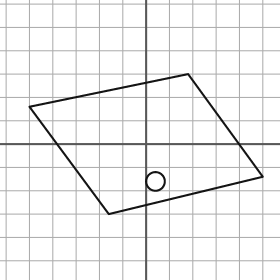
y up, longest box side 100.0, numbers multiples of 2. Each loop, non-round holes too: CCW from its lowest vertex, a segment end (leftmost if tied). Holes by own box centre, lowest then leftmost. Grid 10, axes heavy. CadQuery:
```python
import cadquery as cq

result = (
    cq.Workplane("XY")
    .moveTo(-16.0, -30.0)
    .lineTo(50.0, -14.0)
    .lineTo(18.0, 30.0)
    .lineTo(-50.0, 16.0)
    .close()
    .moveTo(4.0, -16.0)
    .circle(4.0)
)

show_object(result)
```